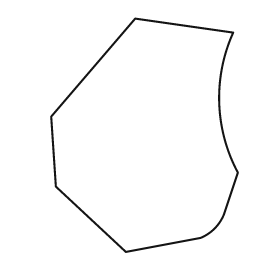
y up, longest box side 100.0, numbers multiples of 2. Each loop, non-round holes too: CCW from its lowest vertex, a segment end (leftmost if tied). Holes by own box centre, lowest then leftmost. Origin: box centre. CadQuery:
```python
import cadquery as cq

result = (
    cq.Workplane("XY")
    .moveTo(-8.0, -50.0)
    .lineTo(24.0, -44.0)
    .threePointArc((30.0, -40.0), (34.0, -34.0))
    .lineTo(40.0, -16.0)
    .threePointArc((32.0, 14.0), (38.0, 44.0))
    .lineTo(-4.0, 50.0)
    .lineTo(-40.0, 8.0)
    .lineTo(-38.0, -22.0)
    .close()
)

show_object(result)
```